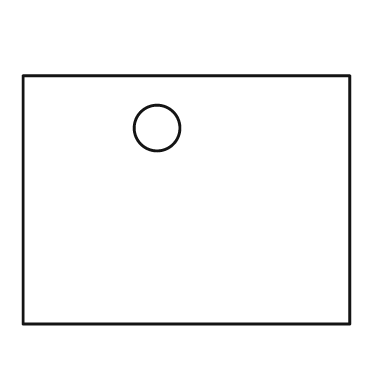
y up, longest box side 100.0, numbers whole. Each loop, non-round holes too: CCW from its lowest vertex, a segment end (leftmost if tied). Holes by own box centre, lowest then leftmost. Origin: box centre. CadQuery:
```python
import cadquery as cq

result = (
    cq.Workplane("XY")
    .moveTo(-50.0, -38.0)
    .lineTo(50.0, -38.0)
    .lineTo(50.0, 38.0)
    .lineTo(-50.0, 38.0)
    .close()
    .moveTo(-9.0, 22.0)
    .circle(7.0)
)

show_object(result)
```